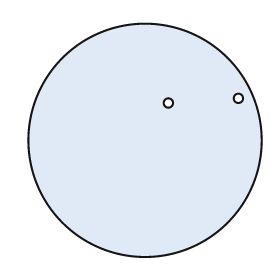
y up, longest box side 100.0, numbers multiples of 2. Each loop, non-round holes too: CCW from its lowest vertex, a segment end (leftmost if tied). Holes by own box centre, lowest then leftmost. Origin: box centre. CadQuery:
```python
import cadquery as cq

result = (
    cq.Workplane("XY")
    .moveTo(0.0, 0.0)
    .circle(50.0)
    .moveTo(10.0, 16.0)
    .circle(2.0)
    .moveTo(40.0, 18.0)
    .circle(2.0)
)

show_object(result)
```